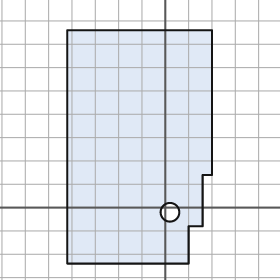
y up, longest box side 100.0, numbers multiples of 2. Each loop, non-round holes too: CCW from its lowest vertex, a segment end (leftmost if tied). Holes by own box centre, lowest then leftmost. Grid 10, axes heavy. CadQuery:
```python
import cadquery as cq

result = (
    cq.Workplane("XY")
    .moveTo(-42.0, -24.0)
    .lineTo(10.0, -24.0)
    .lineTo(10.0, -8.0)
    .lineTo(16.0, -8.0)
    .lineTo(16.0, 14.0)
    .lineTo(20.0, 14.0)
    .lineTo(20.0, 76.0)
    .lineTo(-42.0, 76.0)
    .close()
    .moveTo(2.0, -2.0)
    .circle(4.0)
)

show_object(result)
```